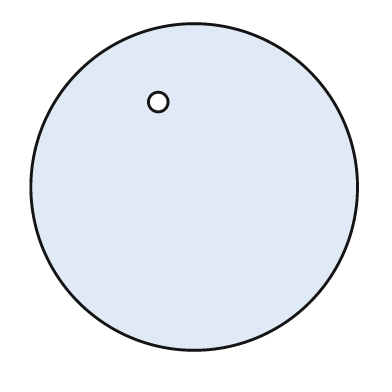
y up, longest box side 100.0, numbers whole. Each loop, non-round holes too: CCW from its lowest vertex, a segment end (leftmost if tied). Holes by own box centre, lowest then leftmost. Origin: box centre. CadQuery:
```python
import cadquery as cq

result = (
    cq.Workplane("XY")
    .moveTo(0.0, 0.0)
    .circle(50.0)
    .moveTo(-11.0, 26.0)
    .circle(3.0)
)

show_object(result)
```